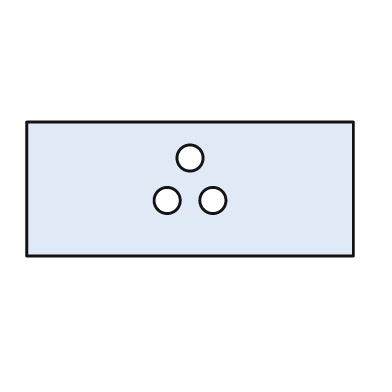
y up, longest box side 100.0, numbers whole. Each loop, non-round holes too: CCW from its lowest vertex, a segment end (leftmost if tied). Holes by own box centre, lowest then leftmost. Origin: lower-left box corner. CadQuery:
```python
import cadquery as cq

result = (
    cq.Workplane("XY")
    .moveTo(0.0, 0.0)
    .lineTo(100.0, 0.0)
    .lineTo(100.0, 41.0)
    .lineTo(0.0, 41.0)
    .close()
    .moveTo(43.0, 17.0)
    .circle(4.0)
    .moveTo(57.0, 17.0)
    .circle(4.0)
    .moveTo(50.0, 30.0)
    .circle(4.0)
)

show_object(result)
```